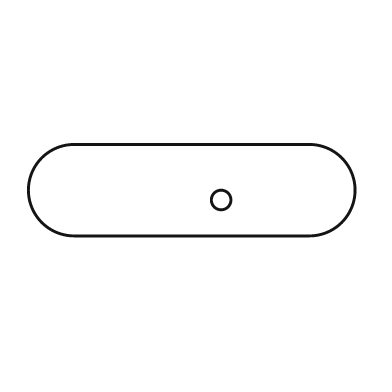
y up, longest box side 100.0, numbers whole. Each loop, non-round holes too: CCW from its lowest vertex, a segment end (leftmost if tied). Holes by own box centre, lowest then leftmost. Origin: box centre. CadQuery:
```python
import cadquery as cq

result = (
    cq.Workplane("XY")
    .moveTo(-36.0, -14.0)
    .lineTo(36.0, -14.0)
    .threePointArc((50.0, 0.0), (36.0, 14.0))
    .lineTo(-36.0, 14.0)
    .threePointArc((-50.0, 0.0), (-36.0, -14.0))
    .close()
    .moveTo(9.0, -3.0)
    .circle(3.0)
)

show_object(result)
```